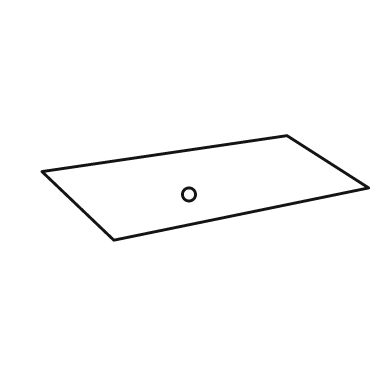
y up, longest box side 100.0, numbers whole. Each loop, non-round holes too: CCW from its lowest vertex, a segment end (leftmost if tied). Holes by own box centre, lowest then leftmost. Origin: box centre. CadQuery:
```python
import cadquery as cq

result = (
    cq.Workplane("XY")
    .moveTo(-28.0, -16.0)
    .lineTo(50.0, 0.0)
    .lineTo(25.0, 16.0)
    .lineTo(-50.0, 5.0)
    .close()
    .moveTo(-5.0, -2.0)
    .circle(2.0)
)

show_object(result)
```